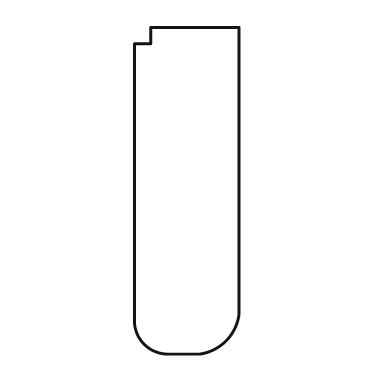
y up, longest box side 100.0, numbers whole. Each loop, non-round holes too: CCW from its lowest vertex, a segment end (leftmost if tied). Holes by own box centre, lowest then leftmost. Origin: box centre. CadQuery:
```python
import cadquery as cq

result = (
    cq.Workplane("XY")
    .moveTo(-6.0, -50.0)
    .lineTo(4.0, -50.0)
    .threePointArc((12.0, -46.0), (16.0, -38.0))
    .lineTo(16.0, 50.0)
    .lineTo(-11.0, 50.0)
    .lineTo(-11.0, 45.0)
    .lineTo(-16.0, 45.0)
    .lineTo(-16.0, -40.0)
    .threePointArc((-13.0, -47.0), (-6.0, -50.0))
    .close()
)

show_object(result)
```